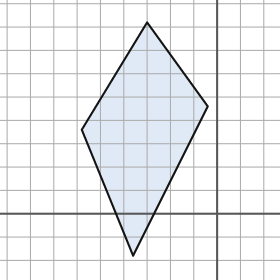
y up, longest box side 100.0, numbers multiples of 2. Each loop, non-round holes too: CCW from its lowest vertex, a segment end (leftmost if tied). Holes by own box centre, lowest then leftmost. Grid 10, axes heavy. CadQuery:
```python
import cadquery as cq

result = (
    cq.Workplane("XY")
    .moveTo(-36.0, -18.0)
    .lineTo(-4.0, 46.0)
    .lineTo(-30.0, 82.0)
    .lineTo(-58.0, 36.0)
    .close()
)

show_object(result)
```